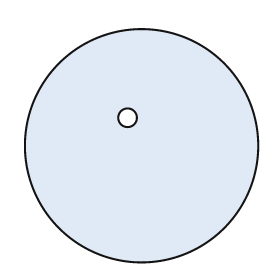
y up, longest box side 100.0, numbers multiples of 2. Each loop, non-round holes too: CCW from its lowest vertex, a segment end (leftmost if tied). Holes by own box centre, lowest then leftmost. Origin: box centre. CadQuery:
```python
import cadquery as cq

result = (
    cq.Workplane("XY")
    .moveTo(0.0, 0.0)
    .circle(50.0)
    .moveTo(-6.0, 12.0)
    .circle(4.0)
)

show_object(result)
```